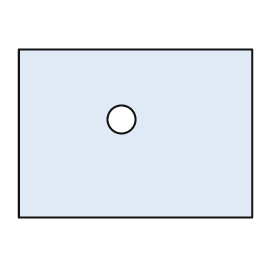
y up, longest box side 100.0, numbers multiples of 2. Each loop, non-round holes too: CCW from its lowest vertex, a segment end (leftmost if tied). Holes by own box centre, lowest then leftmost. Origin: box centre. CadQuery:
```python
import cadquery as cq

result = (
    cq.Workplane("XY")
    .moveTo(-50.0, -36.0)
    .lineTo(50.0, -36.0)
    .lineTo(50.0, 36.0)
    .lineTo(-50.0, 36.0)
    .close()
    .moveTo(-6.0, 6.0)
    .circle(6.0)
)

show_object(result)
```